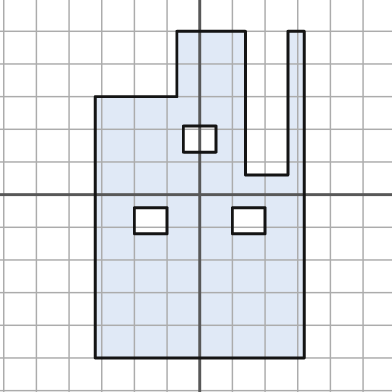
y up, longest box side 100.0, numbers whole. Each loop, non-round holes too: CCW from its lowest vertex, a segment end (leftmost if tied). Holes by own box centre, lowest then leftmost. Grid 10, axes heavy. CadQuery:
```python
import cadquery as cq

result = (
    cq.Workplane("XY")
    .moveTo(-32.0, -50.0)
    .lineTo(32.0, -50.0)
    .lineTo(32.0, 50.0)
    .lineTo(27.0, 50.0)
    .lineTo(27.0, 6.0)
    .lineTo(14.0, 6.0)
    .lineTo(14.0, 50.0)
    .lineTo(-7.0, 50.0)
    .lineTo(-7.0, 30.0)
    .lineTo(-32.0, 30.0)
    .close()
    .moveTo(-20.0, -12.0)
    .lineTo(-10.0, -12.0)
    .lineTo(-10.0, -4.0)
    .lineTo(-20.0, -4.0)
    .close()
    .moveTo(10.0, -12.0)
    .lineTo(20.0, -12.0)
    .lineTo(20.0, -4.0)
    .lineTo(10.0, -4.0)
    .close()
    .moveTo(-5.0, 13.0)
    .lineTo(5.0, 13.0)
    .lineTo(5.0, 21.0)
    .lineTo(-5.0, 21.0)
    .close()
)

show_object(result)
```